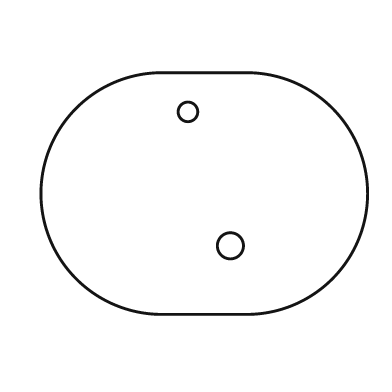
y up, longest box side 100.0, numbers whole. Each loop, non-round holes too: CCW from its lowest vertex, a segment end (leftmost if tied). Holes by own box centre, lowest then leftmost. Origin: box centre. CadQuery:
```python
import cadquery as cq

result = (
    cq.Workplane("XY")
    .moveTo(-13.0, -37.0)
    .lineTo(13.0, -37.0)
    .threePointArc((50.0, 0.0), (13.0, 37.0))
    .lineTo(-13.0, 37.0)
    .threePointArc((-50.0, 0.0), (-13.0, -37.0))
    .close()
    .moveTo(8.0, -16.0)
    .circle(4.0)
    .moveTo(-5.0, 25.0)
    .circle(3.0)
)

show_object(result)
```